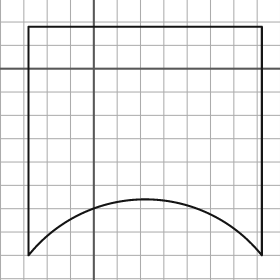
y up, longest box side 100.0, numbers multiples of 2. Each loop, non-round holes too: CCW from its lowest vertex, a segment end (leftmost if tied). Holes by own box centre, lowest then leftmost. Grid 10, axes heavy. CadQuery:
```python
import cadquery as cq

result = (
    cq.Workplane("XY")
    .moveTo(-28.0, -80.0)
    .threePointArc((22.0, -56.0), (72.0, -80.0))
    .lineTo(72.0, 18.0)
    .lineTo(-28.0, 18.0)
    .close()
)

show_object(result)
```